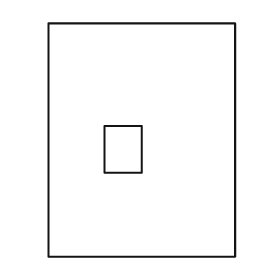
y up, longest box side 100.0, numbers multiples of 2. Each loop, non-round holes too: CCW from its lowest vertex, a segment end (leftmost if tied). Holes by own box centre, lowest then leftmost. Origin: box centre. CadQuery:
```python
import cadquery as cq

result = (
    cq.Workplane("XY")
    .moveTo(-40.0, -50.0)
    .lineTo(40.0, -50.0)
    .lineTo(40.0, 50.0)
    .lineTo(-40.0, 50.0)
    .close()
    .moveTo(-16.0, -14.0)
    .lineTo(0.0, -14.0)
    .lineTo(0.0, 6.0)
    .lineTo(-16.0, 6.0)
    .close()
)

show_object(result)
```